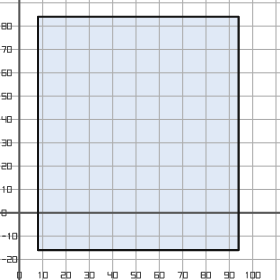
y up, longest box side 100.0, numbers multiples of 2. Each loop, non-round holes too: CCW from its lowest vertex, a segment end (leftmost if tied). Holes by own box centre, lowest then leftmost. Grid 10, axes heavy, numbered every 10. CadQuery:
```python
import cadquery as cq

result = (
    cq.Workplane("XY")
    .moveTo(8.0, -16.0)
    .lineTo(94.0, -16.0)
    .lineTo(94.0, 84.0)
    .lineTo(8.0, 84.0)
    .close()
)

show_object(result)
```